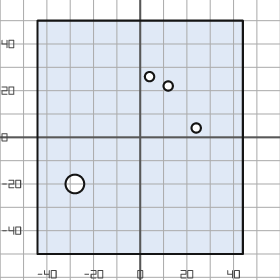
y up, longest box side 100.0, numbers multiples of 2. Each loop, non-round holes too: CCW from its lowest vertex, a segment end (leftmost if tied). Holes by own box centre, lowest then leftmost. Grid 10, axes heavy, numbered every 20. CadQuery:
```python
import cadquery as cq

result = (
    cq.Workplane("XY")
    .moveTo(-44.0, -50.0)
    .lineTo(44.0, -50.0)
    .lineTo(44.0, 50.0)
    .lineTo(-44.0, 50.0)
    .close()
    .moveTo(-28.0, -20.0)
    .circle(4.0)
    .moveTo(24.0, 4.0)
    .circle(2.0)
    .moveTo(12.0, 22.0)
    .circle(2.0)
    .moveTo(4.0, 26.0)
    .circle(2.0)
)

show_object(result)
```